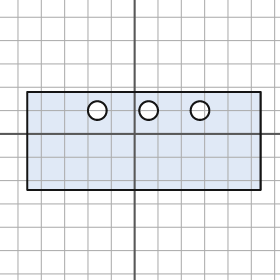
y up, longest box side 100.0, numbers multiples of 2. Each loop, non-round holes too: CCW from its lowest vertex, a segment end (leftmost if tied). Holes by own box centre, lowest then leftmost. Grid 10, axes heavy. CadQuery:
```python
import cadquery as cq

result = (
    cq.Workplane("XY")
    .moveTo(-46.0, -24.0)
    .lineTo(54.0, -24.0)
    .lineTo(54.0, 18.0)
    .lineTo(-46.0, 18.0)
    .close()
    .moveTo(-16.0, 10.0)
    .circle(4.0)
    .moveTo(6.0, 10.0)
    .circle(4.0)
    .moveTo(28.0, 10.0)
    .circle(4.0)
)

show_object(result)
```